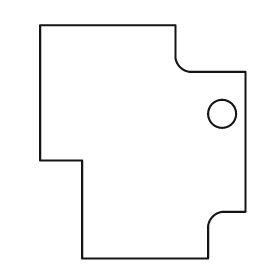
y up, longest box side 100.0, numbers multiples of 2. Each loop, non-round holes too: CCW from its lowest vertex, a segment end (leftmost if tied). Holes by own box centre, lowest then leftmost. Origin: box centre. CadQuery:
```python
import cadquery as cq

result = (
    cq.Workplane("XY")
    .moveTo(-26.0, -50.0)
    .lineTo(28.0, -50.0)
    .lineTo(28.0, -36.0)
    .threePointArc((30.0, -32.0), (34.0, -30.0))
    .lineTo(44.0, -30.0)
    .lineTo(44.0, 30.0)
    .lineTo(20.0, 30.0)
    .threePointArc((16.0, 32.0), (14.0, 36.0))
    .lineTo(14.0, 50.0)
    .lineTo(-44.0, 50.0)
    .lineTo(-44.0, -8.0)
    .lineTo(-26.0, -8.0)
    .close()
    .moveTo(34.0, 12.0)
    .circle(6.0)
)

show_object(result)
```